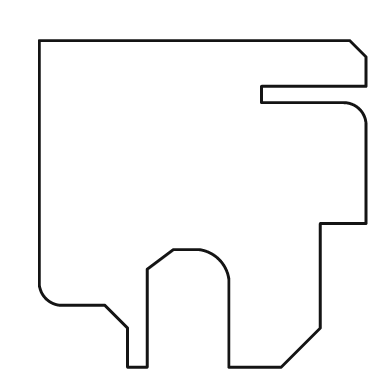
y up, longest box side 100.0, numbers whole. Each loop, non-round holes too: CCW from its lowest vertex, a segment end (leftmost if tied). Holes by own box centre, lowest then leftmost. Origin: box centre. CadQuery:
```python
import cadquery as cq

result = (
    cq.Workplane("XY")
    .moveTo(-23.0, -50.0)
    .lineTo(-17.0, -50.0)
    .lineTo(-17.0, -20.0)
    .lineTo(-9.0, -14.0)
    .lineTo(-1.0, -14.0)
    .threePointArc((5.0, -17.0), (8.0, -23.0))
    .lineTo(8.0, -50.0)
    .lineTo(24.0, -50.0)
    .lineTo(36.0, -38.0)
    .lineTo(36.0, -6.0)
    .lineTo(50.0, -6.0)
    .lineTo(50.0, 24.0)
    .threePointArc((48.0, 29.0), (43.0, 31.0))
    .lineTo(18.0, 31.0)
    .lineTo(18.0, 36.0)
    .lineTo(50.0, 36.0)
    .lineTo(50.0, 45.0)
    .lineTo(45.0, 50.0)
    .lineTo(-50.0, 50.0)
    .lineTo(-50.0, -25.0)
    .threePointArc((-48.0, -29.0), (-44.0, -31.0))
    .lineTo(-30.0, -31.0)
    .lineTo(-23.0, -38.0)
    .close()
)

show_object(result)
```